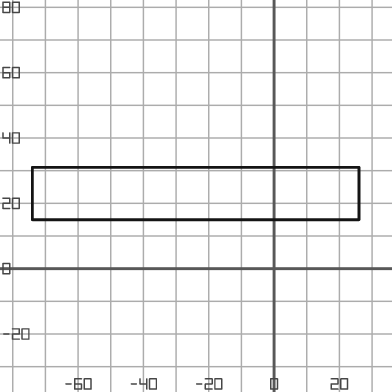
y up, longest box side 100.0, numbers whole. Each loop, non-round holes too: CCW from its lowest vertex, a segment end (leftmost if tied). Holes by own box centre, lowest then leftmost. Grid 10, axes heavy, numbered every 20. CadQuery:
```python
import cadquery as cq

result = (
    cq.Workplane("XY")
    .moveTo(-74.0, 15.0)
    .lineTo(26.0, 15.0)
    .lineTo(26.0, 31.0)
    .lineTo(-74.0, 31.0)
    .close()
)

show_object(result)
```